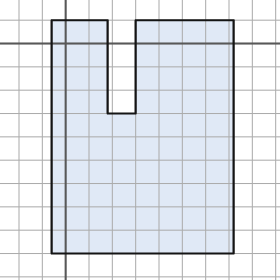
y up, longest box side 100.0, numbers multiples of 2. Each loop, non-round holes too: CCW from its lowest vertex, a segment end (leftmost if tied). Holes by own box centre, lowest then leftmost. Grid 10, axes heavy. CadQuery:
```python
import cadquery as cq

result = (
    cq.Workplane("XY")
    .moveTo(-6.0, -90.0)
    .lineTo(72.0, -90.0)
    .lineTo(72.0, 10.0)
    .lineTo(30.0, 10.0)
    .lineTo(30.0, -30.0)
    .lineTo(18.0, -30.0)
    .lineTo(18.0, 10.0)
    .lineTo(-6.0, 10.0)
    .close()
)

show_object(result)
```